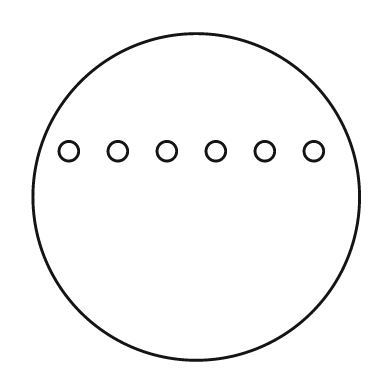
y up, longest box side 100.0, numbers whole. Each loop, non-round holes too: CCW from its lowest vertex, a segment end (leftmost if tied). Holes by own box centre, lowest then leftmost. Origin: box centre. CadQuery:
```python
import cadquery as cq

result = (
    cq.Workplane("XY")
    .moveTo(0.0, 0.0)
    .circle(50.0)
    .moveTo(-39.0, 14.0)
    .circle(3.0)
    .moveTo(-24.0, 14.0)
    .circle(3.0)
    .moveTo(-9.0, 14.0)
    .circle(3.0)
    .moveTo(6.0, 14.0)
    .circle(3.0)
    .moveTo(21.0, 14.0)
    .circle(3.0)
    .moveTo(36.0, 14.0)
    .circle(3.0)
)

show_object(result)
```